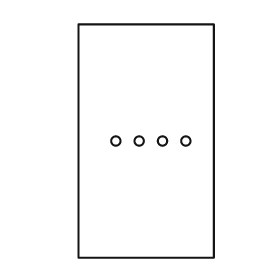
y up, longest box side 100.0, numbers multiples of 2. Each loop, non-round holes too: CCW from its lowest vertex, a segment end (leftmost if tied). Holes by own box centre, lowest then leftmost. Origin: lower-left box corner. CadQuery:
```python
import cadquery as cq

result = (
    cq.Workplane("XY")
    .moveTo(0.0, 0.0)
    .lineTo(58.0, 0.0)
    .lineTo(58.0, 100.0)
    .lineTo(0.0, 100.0)
    .close()
    .moveTo(16.0, 50.0)
    .circle(2.0)
    .moveTo(26.0, 50.0)
    .circle(2.0)
    .moveTo(36.0, 50.0)
    .circle(2.0)
    .moveTo(46.0, 50.0)
    .circle(2.0)
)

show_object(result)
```